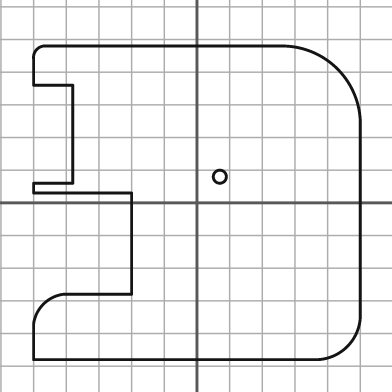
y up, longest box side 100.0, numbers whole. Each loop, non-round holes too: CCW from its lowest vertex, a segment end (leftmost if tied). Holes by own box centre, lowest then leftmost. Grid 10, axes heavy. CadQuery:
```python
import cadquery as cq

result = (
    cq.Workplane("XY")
    .moveTo(-50.0, -48.0)
    .lineTo(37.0, -48.0)
    .threePointArc((46.0, -44.0), (50.0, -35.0))
    .lineTo(50.0, 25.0)
    .threePointArc((43.0, 41.0), (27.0, 48.0))
    .lineTo(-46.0, 48.0)
    .threePointArc((-49.0, 47.0), (-50.0, 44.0))
    .lineTo(-50.0, 36.0)
    .lineTo(-38.0, 36.0)
    .lineTo(-38.0, 6.0)
    .lineTo(-50.0, 6.0)
    .lineTo(-50.0, 3.0)
    .lineTo(-20.0, 3.0)
    .lineTo(-20.0, -28.0)
    .lineTo(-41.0, -28.0)
    .threePointArc((-47.0, -31.0), (-50.0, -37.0))
    .close()
    .moveTo(7.0, 8.0)
    .circle(2.0)
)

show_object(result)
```